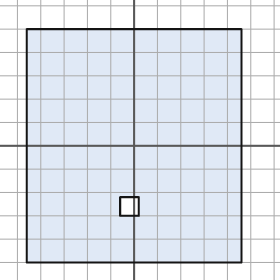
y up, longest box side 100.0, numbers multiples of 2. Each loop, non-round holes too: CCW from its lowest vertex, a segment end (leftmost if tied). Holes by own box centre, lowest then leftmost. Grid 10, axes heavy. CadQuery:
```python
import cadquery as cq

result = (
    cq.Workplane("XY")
    .moveTo(-46.0, -50.0)
    .lineTo(46.0, -50.0)
    .lineTo(46.0, 50.0)
    .lineTo(-46.0, 50.0)
    .close()
    .moveTo(-6.0, -30.0)
    .lineTo(2.0, -30.0)
    .lineTo(2.0, -22.0)
    .lineTo(-6.0, -22.0)
    .close()
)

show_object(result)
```